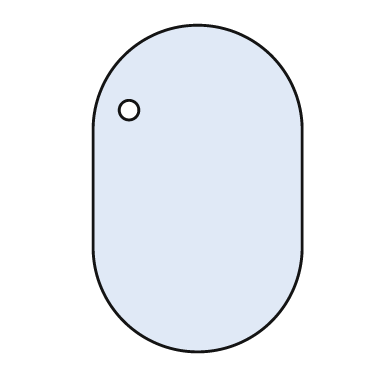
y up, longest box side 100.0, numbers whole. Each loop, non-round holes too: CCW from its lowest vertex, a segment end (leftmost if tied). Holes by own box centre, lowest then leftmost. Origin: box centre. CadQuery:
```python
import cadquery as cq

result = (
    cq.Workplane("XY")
    .moveTo(-32.0, -18.0)
    .threePointArc((0.0, -50.0), (32.0, -18.0))
    .lineTo(32.0, 18.0)
    .threePointArc((0.0, 50.0), (-32.0, 18.0))
    .close()
    .moveTo(-21.0, 24.0)
    .circle(3.0)
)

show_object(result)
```